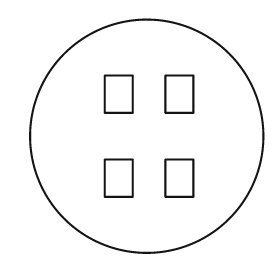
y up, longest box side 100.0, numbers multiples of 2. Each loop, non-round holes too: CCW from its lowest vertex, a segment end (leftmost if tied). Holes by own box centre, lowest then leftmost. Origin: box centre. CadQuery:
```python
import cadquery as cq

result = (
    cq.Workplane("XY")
    .moveTo(0.0, 0.0)
    .circle(50.0)
    .moveTo(-18.0, -26.0)
    .lineTo(-6.0, -26.0)
    .lineTo(-6.0, -10.0)
    .lineTo(-18.0, -10.0)
    .close()
    .moveTo(8.0, -26.0)
    .lineTo(20.0, -26.0)
    .lineTo(20.0, -10.0)
    .lineTo(8.0, -10.0)
    .close()
    .moveTo(-18.0, 10.0)
    .lineTo(-6.0, 10.0)
    .lineTo(-6.0, 26.0)
    .lineTo(-18.0, 26.0)
    .close()
    .moveTo(8.0, 10.0)
    .lineTo(20.0, 10.0)
    .lineTo(20.0, 26.0)
    .lineTo(8.0, 26.0)
    .close()
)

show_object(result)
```